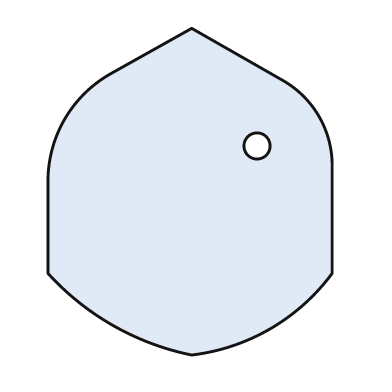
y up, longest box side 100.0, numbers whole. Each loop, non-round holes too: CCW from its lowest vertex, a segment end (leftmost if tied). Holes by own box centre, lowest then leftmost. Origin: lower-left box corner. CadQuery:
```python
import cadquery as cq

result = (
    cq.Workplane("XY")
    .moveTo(44.0, 0.0)
    .threePointArc((68.0, 8.0), (87.0, 25.0))
    .lineTo(87.0, 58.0)
    .threePointArc((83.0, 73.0), (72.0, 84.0))
    .lineTo(44.0, 100.0)
    .lineTo(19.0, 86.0)
    .threePointArc((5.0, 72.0), (0.0, 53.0))
    .lineTo(0.0, 25.0)
    .threePointArc((20.0, 9.0), (44.0, 0.0))
    .close()
    .moveTo(64.0, 64.0)
    .circle(4.0)
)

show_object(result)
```